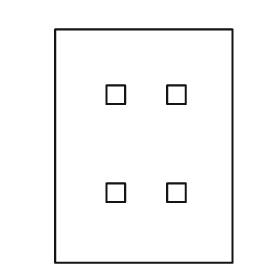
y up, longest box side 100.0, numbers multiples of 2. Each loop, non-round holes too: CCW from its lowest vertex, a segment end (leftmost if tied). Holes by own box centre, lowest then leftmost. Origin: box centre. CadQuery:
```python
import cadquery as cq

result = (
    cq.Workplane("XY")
    .moveTo(-38.0, -50.0)
    .lineTo(38.0, -50.0)
    .lineTo(38.0, 50.0)
    .lineTo(-38.0, 50.0)
    .close()
    .moveTo(-16.0, -24.0)
    .lineTo(-8.0, -24.0)
    .lineTo(-8.0, -16.0)
    .lineTo(-16.0, -16.0)
    .close()
    .moveTo(10.0, -24.0)
    .lineTo(18.0, -24.0)
    .lineTo(18.0, -16.0)
    .lineTo(10.0, -16.0)
    .close()
    .moveTo(-16.0, 18.0)
    .lineTo(-8.0, 18.0)
    .lineTo(-8.0, 26.0)
    .lineTo(-16.0, 26.0)
    .close()
    .moveTo(10.0, 18.0)
    .lineTo(18.0, 18.0)
    .lineTo(18.0, 26.0)
    .lineTo(10.0, 26.0)
    .close()
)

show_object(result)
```